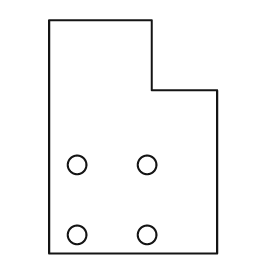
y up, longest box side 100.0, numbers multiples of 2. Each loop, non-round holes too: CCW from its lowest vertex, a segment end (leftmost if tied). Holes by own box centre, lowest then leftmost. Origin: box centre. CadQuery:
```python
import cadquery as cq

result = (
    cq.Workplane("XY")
    .moveTo(-36.0, -50.0)
    .lineTo(36.0, -50.0)
    .lineTo(36.0, 20.0)
    .lineTo(8.0, 20.0)
    .lineTo(8.0, 50.0)
    .lineTo(-36.0, 50.0)
    .close()
    .moveTo(-24.0, -42.0)
    .circle(4.0)
    .moveTo(6.0, -42.0)
    .circle(4.0)
    .moveTo(-24.0, -12.0)
    .circle(4.0)
    .moveTo(6.0, -12.0)
    .circle(4.0)
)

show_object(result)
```